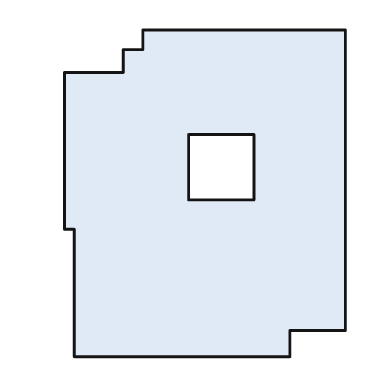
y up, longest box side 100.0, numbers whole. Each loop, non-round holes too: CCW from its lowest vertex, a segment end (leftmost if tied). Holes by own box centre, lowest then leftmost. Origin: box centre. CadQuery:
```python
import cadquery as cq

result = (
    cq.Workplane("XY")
    .moveTo(-40.0, -50.0)
    .lineTo(26.0, -50.0)
    .lineTo(26.0, -42.0)
    .lineTo(43.0, -42.0)
    .lineTo(43.0, 50.0)
    .lineTo(-19.0, 50.0)
    .lineTo(-19.0, 44.0)
    .lineTo(-25.0, 44.0)
    .lineTo(-25.0, 37.0)
    .lineTo(-43.0, 37.0)
    .lineTo(-43.0, -11.0)
    .lineTo(-40.0, -11.0)
    .close()
    .moveTo(-5.0, -2.0)
    .lineTo(15.0, -2.0)
    .lineTo(15.0, 18.0)
    .lineTo(-5.0, 18.0)
    .close()
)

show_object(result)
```